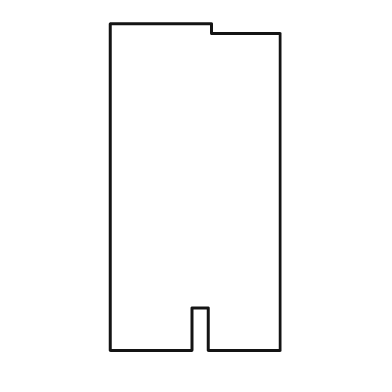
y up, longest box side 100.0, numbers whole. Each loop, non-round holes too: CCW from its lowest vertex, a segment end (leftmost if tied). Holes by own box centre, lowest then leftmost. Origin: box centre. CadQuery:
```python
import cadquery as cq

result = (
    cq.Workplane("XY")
    .moveTo(-26.0, -50.0)
    .lineTo(-1.0, -50.0)
    .lineTo(-1.0, -37.0)
    .lineTo(4.0, -37.0)
    .lineTo(4.0, -50.0)
    .lineTo(26.0, -50.0)
    .lineTo(26.0, 47.0)
    .lineTo(5.0, 47.0)
    .lineTo(5.0, 50.0)
    .lineTo(-26.0, 50.0)
    .close()
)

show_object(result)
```